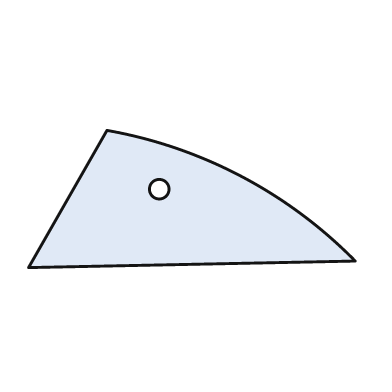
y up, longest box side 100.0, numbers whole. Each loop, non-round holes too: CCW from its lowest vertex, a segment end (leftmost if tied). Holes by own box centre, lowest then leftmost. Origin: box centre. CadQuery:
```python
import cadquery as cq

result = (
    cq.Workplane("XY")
    .moveTo(-50.0, -21.0)
    .lineTo(50.0, -19.0)
    .threePointArc((15.0, 7.0), (-26.0, 21.0))
    .close()
    .moveTo(-10.0, 3.0)
    .circle(3.0)
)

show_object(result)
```